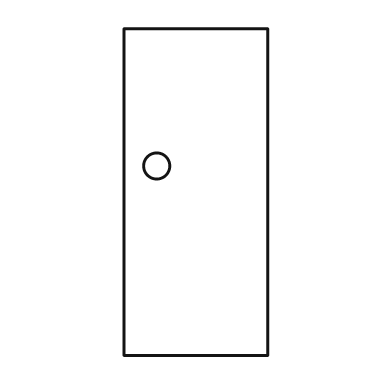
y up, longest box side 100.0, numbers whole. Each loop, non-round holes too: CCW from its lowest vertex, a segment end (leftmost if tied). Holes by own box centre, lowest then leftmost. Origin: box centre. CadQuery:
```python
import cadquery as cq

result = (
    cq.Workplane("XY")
    .moveTo(-22.0, -50.0)
    .lineTo(22.0, -50.0)
    .lineTo(22.0, 50.0)
    .lineTo(-22.0, 50.0)
    .close()
    .moveTo(-12.0, 8.0)
    .circle(4.0)
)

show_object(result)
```